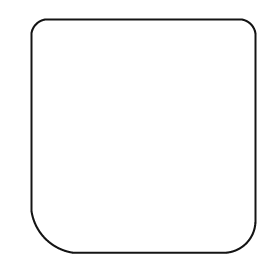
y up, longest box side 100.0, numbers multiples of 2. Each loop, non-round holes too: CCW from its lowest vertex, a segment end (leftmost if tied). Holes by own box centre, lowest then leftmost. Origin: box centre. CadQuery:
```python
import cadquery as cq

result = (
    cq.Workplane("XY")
    .moveTo(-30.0, -50.0)
    .lineTo(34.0, -50.0)
    .threePointArc((44.0, -46.0), (48.0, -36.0))
    .lineTo(48.0, 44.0)
    .threePointArc((46.0, 48.0), (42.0, 50.0))
    .lineTo(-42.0, 50.0)
    .threePointArc((-46.0, 48.0), (-48.0, 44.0))
    .lineTo(-48.0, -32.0)
    .threePointArc((-42.0, -44.0), (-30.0, -50.0))
    .close()
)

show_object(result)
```